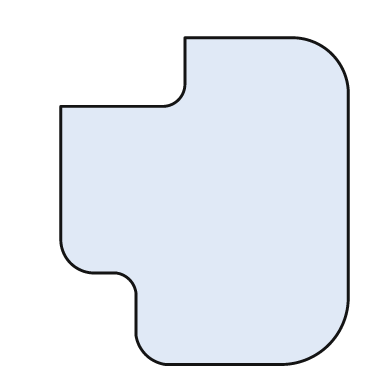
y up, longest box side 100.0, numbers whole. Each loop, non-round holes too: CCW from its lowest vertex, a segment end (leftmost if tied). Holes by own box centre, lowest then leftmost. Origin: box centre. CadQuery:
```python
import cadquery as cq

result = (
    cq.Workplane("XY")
    .moveTo(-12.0, -50.0)
    .lineTo(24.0, -50.0)
    .threePointArc((38.0, -44.0), (44.0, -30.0))
    .lineTo(44.0, 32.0)
    .threePointArc((39.0, 45.0), (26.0, 50.0))
    .lineTo(-6.0, 50.0)
    .lineTo(-6.0, 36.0)
    .threePointArc((-8.0, 31.0), (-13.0, 29.0))
    .lineTo(-44.0, 29.0)
    .lineTo(-44.0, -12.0)
    .threePointArc((-41.0, -19.0), (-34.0, -22.0))
    .lineTo(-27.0, -22.0)
    .threePointArc((-23.0, -24.0), (-21.0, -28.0))
    .lineTo(-21.0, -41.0)
    .threePointArc((-18.0, -47.0), (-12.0, -50.0))
    .close()
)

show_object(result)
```